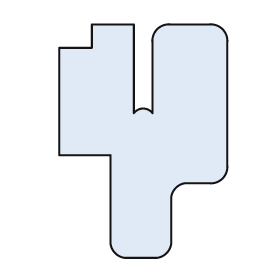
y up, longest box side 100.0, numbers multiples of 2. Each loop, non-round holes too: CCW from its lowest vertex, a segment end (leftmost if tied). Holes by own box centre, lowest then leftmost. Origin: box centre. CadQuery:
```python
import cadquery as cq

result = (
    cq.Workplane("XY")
    .moveTo(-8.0, -50.0)
    .lineTo(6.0, -50.0)
    .threePointArc((10.0, -48.0), (12.0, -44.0))
    .lineTo(12.0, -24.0)
    .threePointArc((14.0, -20.0), (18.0, -18.0))
    .lineTo(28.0, -18.0)
    .threePointArc((34.0, -16.0), (36.0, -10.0))
    .lineTo(36.0, 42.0)
    .threePointArc((34.0, 48.0), (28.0, 50.0))
    .lineTo(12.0, 50.0)
    .threePointArc((6.0, 48.0), (4.0, 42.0))
    .lineTo(4.0, 12.0)
    .threePointArc((0.0, 14.0), (-4.0, 12.0))
    .lineTo(-4.0, 50.0)
    .lineTo(-22.0, 50.0)
    .lineTo(-22.0, 40.0)
    .lineTo(-36.0, 40.0)
    .lineTo(-36.0, -6.0)
    .lineTo(-14.0, -6.0)
    .lineTo(-14.0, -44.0)
    .threePointArc((-12.0, -48.0), (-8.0, -50.0))
    .close()
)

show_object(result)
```